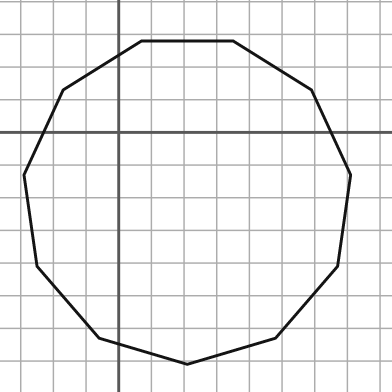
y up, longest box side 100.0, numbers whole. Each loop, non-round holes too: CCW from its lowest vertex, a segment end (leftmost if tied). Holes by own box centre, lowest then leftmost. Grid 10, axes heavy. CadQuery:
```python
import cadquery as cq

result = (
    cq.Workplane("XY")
    .moveTo(21.0, -71.0)
    .lineTo(48.0, -63.0)
    .lineTo(67.0, -41.0)
    .lineTo(71.0, -13.0)
    .lineTo(59.0, 13.0)
    .lineTo(35.0, 28.0)
    .lineTo(7.0, 28.0)
    .lineTo(-17.0, 13.0)
    .lineTo(-29.0, -13.0)
    .lineTo(-25.0, -41.0)
    .lineTo(-6.0, -63.0)
    .close()
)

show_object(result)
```